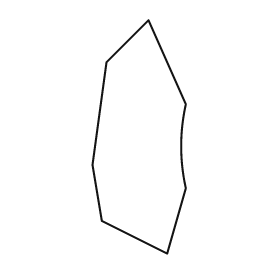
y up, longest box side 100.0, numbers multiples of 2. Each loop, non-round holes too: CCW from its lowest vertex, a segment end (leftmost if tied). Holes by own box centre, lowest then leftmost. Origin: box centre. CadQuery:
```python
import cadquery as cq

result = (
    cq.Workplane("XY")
    .moveTo(12.0, -50.0)
    .lineTo(20.0, -22.0)
    .threePointArc((18.0, -4.0), (20.0, 14.0))
    .lineTo(4.0, 50.0)
    .lineTo(-14.0, 32.0)
    .lineTo(-20.0, -12.0)
    .lineTo(-16.0, -36.0)
    .close()
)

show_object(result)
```